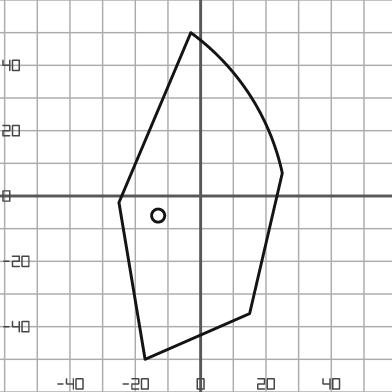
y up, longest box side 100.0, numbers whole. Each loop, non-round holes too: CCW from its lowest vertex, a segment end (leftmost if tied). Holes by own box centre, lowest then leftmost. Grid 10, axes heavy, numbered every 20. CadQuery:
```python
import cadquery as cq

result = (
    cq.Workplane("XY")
    .moveTo(-17.0, -50.0)
    .lineTo(15.0, -36.0)
    .lineTo(25.0, 7.0)
    .threePointArc((15.0, 31.0), (-3.0, 50.0))
    .lineTo(-25.0, -2.0)
    .close()
    .moveTo(-13.0, -6.0)
    .circle(2.0)
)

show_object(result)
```